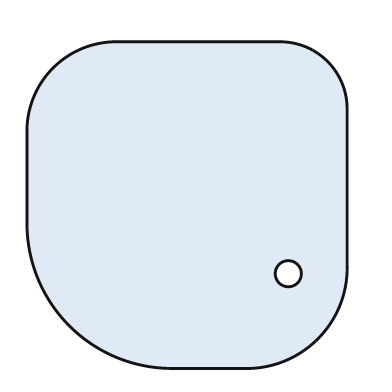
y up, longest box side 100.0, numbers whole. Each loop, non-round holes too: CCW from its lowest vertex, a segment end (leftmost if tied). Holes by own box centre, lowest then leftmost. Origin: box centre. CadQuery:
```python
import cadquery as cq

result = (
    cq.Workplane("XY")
    .moveTo(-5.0, -50.0)
    .lineTo(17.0, -50.0)
    .threePointArc((40.0, -41.0), (49.0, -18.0))
    .lineTo(49.0, 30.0)
    .threePointArc((43.0, 44.0), (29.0, 50.0))
    .lineTo(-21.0, 50.0)
    .threePointArc((-41.0, 42.0), (-49.0, 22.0))
    .lineTo(-49.0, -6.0)
    .threePointArc((-36.0, -37.0), (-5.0, -50.0))
    .close()
    .moveTo(31.0, -21.0)
    .circle(4.0)
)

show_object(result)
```